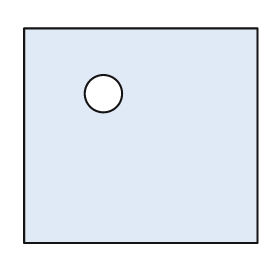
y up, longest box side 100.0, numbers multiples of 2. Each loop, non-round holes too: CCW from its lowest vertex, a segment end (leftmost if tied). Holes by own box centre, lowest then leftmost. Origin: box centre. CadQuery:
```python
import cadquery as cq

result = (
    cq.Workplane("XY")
    .moveTo(-50.0, -46.0)
    .lineTo(50.0, -46.0)
    .lineTo(50.0, 46.0)
    .lineTo(-50.0, 46.0)
    .close()
    .moveTo(-16.0, 18.0)
    .circle(8.0)
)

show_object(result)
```